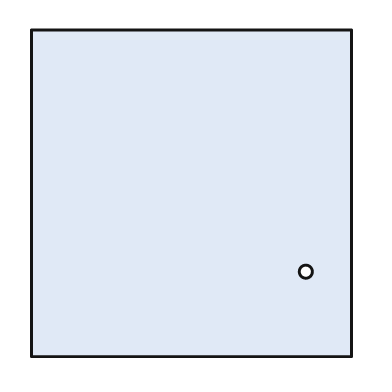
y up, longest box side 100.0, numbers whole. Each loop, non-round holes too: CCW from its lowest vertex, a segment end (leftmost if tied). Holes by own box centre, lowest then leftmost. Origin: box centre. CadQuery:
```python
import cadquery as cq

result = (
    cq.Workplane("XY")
    .moveTo(-49.0, -50.0)
    .lineTo(49.0, -50.0)
    .lineTo(49.0, 50.0)
    .lineTo(-49.0, 50.0)
    .close()
    .moveTo(35.0, -24.0)
    .circle(2.0)
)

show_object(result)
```